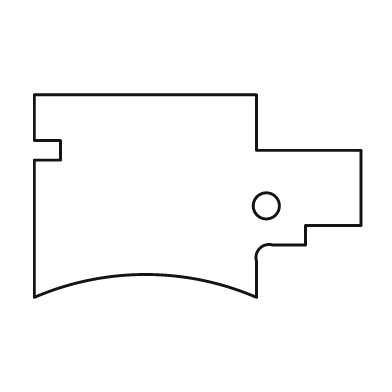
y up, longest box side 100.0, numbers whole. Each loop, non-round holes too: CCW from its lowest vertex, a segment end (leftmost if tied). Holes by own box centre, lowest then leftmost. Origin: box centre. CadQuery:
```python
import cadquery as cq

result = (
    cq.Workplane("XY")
    .moveTo(-50.0, -31.0)
    .threePointArc((-16.0, -24.0), (18.0, -31.0))
    .lineTo(18.0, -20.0)
    .threePointArc((19.0, -16.0), (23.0, -15.0))
    .lineTo(33.0, -15.0)
    .lineTo(33.0, -9.0)
    .lineTo(50.0, -9.0)
    .lineTo(50.0, 14.0)
    .lineTo(18.0, 14.0)
    .lineTo(18.0, 31.0)
    .lineTo(-50.0, 31.0)
    .lineTo(-50.0, 17.0)
    .lineTo(-42.0, 17.0)
    .lineTo(-42.0, 11.0)
    .lineTo(-50.0, 11.0)
    .close()
    .moveTo(21.0, -3.0)
    .circle(4.0)
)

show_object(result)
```